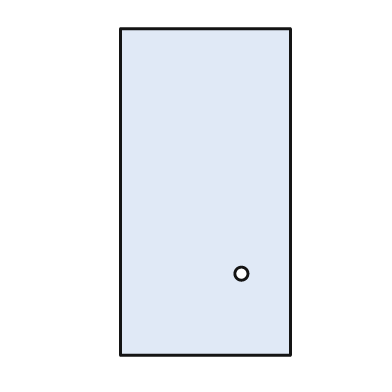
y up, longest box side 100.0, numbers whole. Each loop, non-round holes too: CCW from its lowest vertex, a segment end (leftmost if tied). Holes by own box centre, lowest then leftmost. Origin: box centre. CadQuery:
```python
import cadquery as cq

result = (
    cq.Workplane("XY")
    .moveTo(-26.0, -50.0)
    .lineTo(26.0, -50.0)
    .lineTo(26.0, 50.0)
    .lineTo(-26.0, 50.0)
    .close()
    .moveTo(11.0, -25.0)
    .circle(2.0)
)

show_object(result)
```